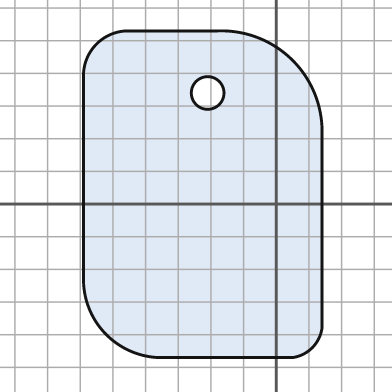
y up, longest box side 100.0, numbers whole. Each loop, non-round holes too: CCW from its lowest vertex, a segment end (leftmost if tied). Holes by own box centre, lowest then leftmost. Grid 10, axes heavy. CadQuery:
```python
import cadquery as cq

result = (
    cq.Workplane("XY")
    .moveTo(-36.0, -47.0)
    .lineTo(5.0, -47.0)
    .threePointArc((11.0, -44.0), (14.0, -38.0))
    .lineTo(14.0, 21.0)
    .threePointArc((5.0, 44.0), (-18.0, 53.0))
    .lineTo(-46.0, 53.0)
    .threePointArc((-55.0, 49.0), (-59.0, 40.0))
    .lineTo(-59.0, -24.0)
    .threePointArc((-52.0, -40.0), (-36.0, -47.0))
    .close()
    .moveTo(-21.0, 34.0)
    .circle(5.0)
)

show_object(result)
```